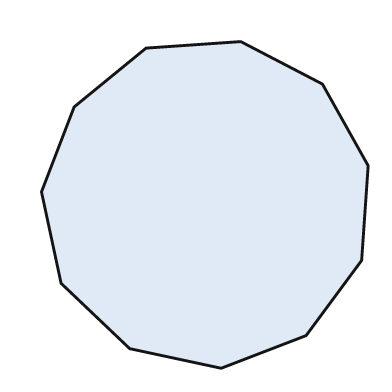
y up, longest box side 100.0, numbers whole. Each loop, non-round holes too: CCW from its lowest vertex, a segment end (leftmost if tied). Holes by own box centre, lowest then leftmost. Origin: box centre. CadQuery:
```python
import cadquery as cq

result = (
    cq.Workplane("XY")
    .moveTo(5.0, -50.0)
    .lineTo(31.0, -40.0)
    .lineTo(48.0, -17.0)
    .lineTo(50.0, 12.0)
    .lineTo(36.0, 37.0)
    .lineTo(11.0, 50.0)
    .lineTo(-18.0, 48.0)
    .lineTo(-40.0, 30.0)
    .lineTo(-50.0, 4.0)
    .lineTo(-44.0, -24.0)
    .lineTo(-23.0, -44.0)
    .close()
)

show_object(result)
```